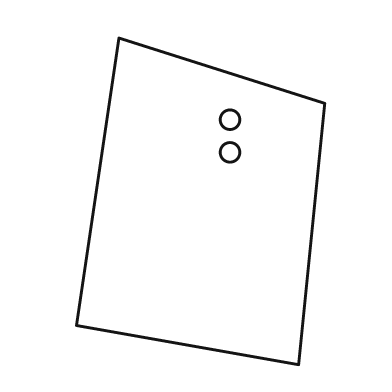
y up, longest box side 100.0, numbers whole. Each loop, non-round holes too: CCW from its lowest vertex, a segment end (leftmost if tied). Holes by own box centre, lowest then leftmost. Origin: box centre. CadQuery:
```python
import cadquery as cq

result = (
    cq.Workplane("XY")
    .moveTo(30.0, -50.0)
    .lineTo(38.0, 30.0)
    .lineTo(-25.0, 50.0)
    .lineTo(-38.0, -38.0)
    .close()
    .moveTo(9.0, 15.0)
    .circle(3.0)
    .moveTo(9.0, 25.0)
    .circle(3.0)
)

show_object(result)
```